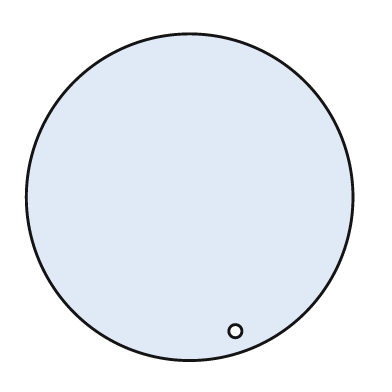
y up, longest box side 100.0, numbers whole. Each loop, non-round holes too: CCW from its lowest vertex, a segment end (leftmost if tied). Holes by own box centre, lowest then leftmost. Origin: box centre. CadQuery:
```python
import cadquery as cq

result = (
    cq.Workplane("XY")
    .moveTo(0.0, 0.0)
    .circle(50.0)
    .moveTo(14.0, -41.0)
    .circle(2.0)
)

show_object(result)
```